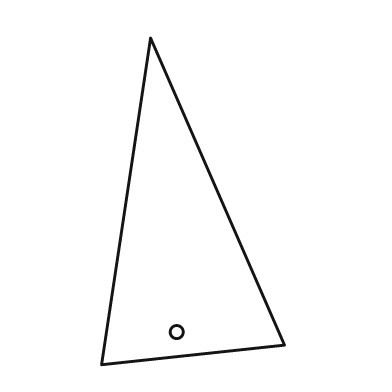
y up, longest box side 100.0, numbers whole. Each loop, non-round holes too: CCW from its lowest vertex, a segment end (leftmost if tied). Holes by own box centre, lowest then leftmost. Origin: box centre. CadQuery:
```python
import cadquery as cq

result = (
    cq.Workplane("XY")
    .moveTo(-28.0, -50.0)
    .lineTo(28.0, -44.0)
    .lineTo(-13.0, 50.0)
    .close()
    .moveTo(-5.0, -40.0)
    .circle(2.0)
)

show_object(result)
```